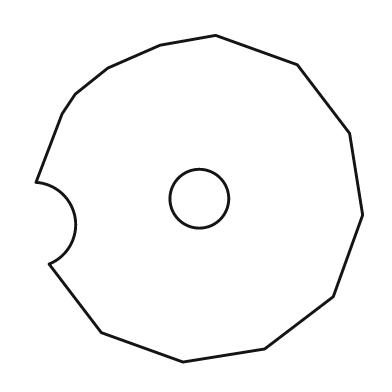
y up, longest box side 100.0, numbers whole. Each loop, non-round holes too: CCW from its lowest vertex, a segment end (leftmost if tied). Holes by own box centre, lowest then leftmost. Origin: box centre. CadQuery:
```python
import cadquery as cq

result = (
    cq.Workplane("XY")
    .moveTo(-5.0, -50.0)
    .lineTo(20.0, -46.0)
    .lineTo(41.0, -30.0)
    .lineTo(50.0, -5.0)
    .lineTo(46.0, 20.0)
    .lineTo(30.0, 41.0)
    .lineTo(5.0, 50.0)
    .lineTo(-12.0, 47.0)
    .lineTo(-28.0, 40.0)
    .lineTo(-38.0, 32.0)
    .lineTo(-42.0, 26.0)
    .lineTo(-50.0, 5.0)
    .threePointArc((-38.0, -6.0), (-46.0, -20.0))
    .lineTo(-30.0, -41.0)
    .close()
    .moveTo(0.0, 0.0)
    .circle(9.0)
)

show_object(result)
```